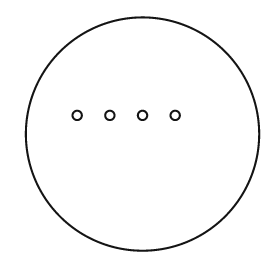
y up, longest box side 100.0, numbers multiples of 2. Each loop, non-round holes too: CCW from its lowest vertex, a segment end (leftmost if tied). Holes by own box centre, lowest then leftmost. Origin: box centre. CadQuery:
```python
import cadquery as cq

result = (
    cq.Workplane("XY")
    .moveTo(0.0, 0.0)
    .circle(50.0)
    .moveTo(-28.0, 8.0)
    .circle(2.0)
    .moveTo(-14.0, 8.0)
    .circle(2.0)
    .moveTo(0.0, 8.0)
    .circle(2.0)
    .moveTo(14.0, 8.0)
    .circle(2.0)
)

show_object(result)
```